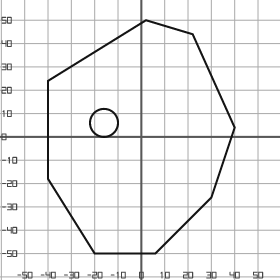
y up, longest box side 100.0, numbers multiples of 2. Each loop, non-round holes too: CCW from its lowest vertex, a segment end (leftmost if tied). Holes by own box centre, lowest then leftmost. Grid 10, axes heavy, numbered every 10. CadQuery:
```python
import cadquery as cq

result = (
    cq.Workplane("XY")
    .moveTo(-20.0, -50.0)
    .lineTo(6.0, -50.0)
    .lineTo(30.0, -26.0)
    .lineTo(40.0, 4.0)
    .lineTo(22.0, 44.0)
    .lineTo(2.0, 50.0)
    .lineTo(-40.0, 24.0)
    .lineTo(-40.0, -18.0)
    .close()
    .moveTo(-16.0, 6.0)
    .circle(6.0)
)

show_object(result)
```